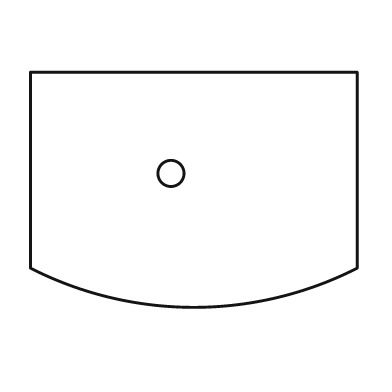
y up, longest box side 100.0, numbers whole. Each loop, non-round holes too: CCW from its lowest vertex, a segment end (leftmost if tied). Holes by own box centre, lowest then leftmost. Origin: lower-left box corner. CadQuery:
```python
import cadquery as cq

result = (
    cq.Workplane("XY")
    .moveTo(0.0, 12.0)
    .threePointArc((50.0, 0.0), (100.0, 12.0))
    .lineTo(100.0, 72.0)
    .lineTo(0.0, 72.0)
    .close()
    .moveTo(43.0, 41.0)
    .circle(4.0)
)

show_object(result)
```